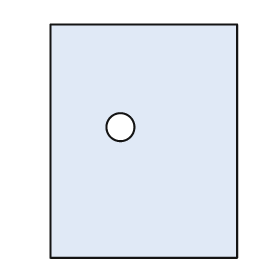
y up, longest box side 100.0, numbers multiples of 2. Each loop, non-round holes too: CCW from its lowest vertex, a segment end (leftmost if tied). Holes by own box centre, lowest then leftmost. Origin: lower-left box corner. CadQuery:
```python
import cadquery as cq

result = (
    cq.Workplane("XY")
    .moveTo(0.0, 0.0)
    .lineTo(80.0, 0.0)
    .lineTo(80.0, 100.0)
    .lineTo(0.0, 100.0)
    .close()
    .moveTo(30.0, 56.0)
    .circle(6.0)
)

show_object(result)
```